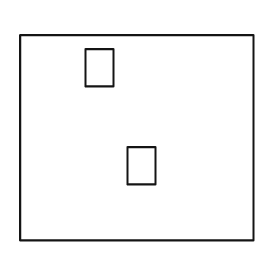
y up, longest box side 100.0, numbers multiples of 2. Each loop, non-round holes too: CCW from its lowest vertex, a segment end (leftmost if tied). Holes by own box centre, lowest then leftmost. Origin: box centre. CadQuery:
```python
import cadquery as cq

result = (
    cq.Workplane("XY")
    .moveTo(-50.0, -44.0)
    .lineTo(50.0, -44.0)
    .lineTo(50.0, 44.0)
    .lineTo(-50.0, 44.0)
    .close()
    .moveTo(-4.0, -20.0)
    .lineTo(8.0, -20.0)
    .lineTo(8.0, -4.0)
    .lineTo(-4.0, -4.0)
    .close()
    .moveTo(-22.0, 22.0)
    .lineTo(-10.0, 22.0)
    .lineTo(-10.0, 38.0)
    .lineTo(-22.0, 38.0)
    .close()
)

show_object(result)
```